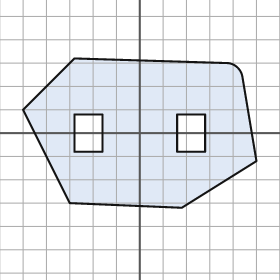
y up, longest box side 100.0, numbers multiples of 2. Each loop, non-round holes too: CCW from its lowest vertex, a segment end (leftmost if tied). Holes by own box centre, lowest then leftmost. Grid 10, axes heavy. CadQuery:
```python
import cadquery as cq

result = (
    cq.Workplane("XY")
    .moveTo(18.0, -32.0)
    .lineTo(50.0, -12.0)
    .lineTo(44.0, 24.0)
    .threePointArc((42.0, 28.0), (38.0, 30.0))
    .lineTo(-28.0, 32.0)
    .lineTo(-50.0, 10.0)
    .lineTo(-30.0, -30.0)
    .close()
    .moveTo(-28.0, -8.0)
    .lineTo(-16.0, -8.0)
    .lineTo(-16.0, 8.0)
    .lineTo(-28.0, 8.0)
    .close()
    .moveTo(16.0, -8.0)
    .lineTo(28.0, -8.0)
    .lineTo(28.0, 8.0)
    .lineTo(16.0, 8.0)
    .close()
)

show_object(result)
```